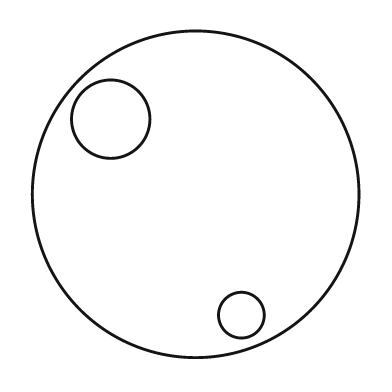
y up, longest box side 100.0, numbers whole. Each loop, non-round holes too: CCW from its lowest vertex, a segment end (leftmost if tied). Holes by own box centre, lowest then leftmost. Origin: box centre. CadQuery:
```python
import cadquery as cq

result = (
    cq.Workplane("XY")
    .moveTo(0.0, 0.0)
    .circle(50.0)
    .moveTo(14.0, -37.0)
    .circle(7.0)
    .moveTo(-26.0, 23.0)
    .circle(12.0)
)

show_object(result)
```